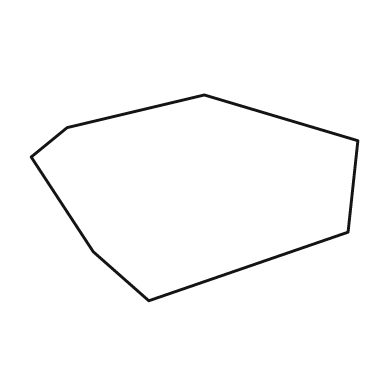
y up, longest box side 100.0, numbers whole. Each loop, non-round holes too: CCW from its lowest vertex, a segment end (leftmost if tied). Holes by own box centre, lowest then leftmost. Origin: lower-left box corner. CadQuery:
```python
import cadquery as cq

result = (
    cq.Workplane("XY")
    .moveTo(36.0, 0.0)
    .lineTo(97.0, 21.0)
    .lineTo(100.0, 49.0)
    .lineTo(53.0, 63.0)
    .lineTo(11.0, 53.0)
    .lineTo(0.0, 44.0)
    .lineTo(19.0, 15.0)
    .close()
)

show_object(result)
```